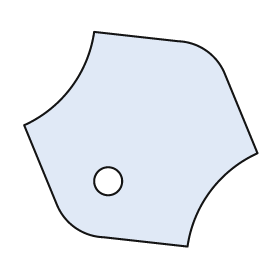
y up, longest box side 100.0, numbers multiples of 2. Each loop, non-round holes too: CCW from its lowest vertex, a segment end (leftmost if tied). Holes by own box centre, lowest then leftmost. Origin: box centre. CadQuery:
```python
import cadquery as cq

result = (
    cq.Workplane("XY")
    .moveTo(20.0, -46.0)
    .threePointArc((30.0, -22.0), (50.0, -6.0))
    .lineTo(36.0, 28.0)
    .threePointArc((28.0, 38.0), (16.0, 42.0))
    .lineTo(-20.0, 46.0)
    .threePointArc((-30.0, 22.0), (-50.0, 6.0))
    .lineTo(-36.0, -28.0)
    .threePointArc((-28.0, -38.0), (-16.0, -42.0))
    .close()
    .moveTo(-14.0, -18.0)
    .circle(6.0)
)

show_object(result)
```